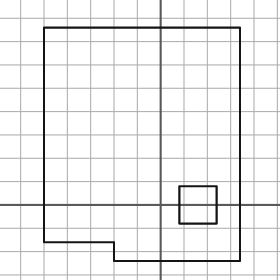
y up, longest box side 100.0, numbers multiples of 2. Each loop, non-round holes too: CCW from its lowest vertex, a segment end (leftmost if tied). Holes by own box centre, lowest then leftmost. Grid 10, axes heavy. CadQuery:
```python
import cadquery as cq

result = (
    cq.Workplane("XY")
    .moveTo(-20.0, -24.0)
    .lineTo(34.0, -24.0)
    .lineTo(34.0, 76.0)
    .lineTo(-50.0, 76.0)
    .lineTo(-50.0, -16.0)
    .lineTo(-20.0, -16.0)
    .close()
    .moveTo(8.0, -8.0)
    .lineTo(24.0, -8.0)
    .lineTo(24.0, 8.0)
    .lineTo(8.0, 8.0)
    .close()
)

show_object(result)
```